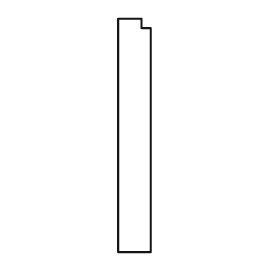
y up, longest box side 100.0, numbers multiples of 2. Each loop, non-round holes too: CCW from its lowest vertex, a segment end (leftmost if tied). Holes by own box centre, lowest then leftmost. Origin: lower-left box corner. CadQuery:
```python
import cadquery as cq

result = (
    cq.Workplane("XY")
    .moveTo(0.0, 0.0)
    .lineTo(14.0, 0.0)
    .lineTo(14.0, 96.0)
    .lineTo(10.0, 96.0)
    .lineTo(10.0, 100.0)
    .lineTo(0.0, 100.0)
    .close()
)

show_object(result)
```